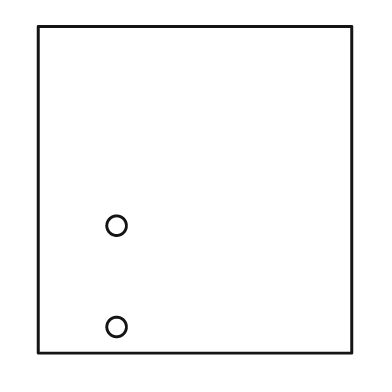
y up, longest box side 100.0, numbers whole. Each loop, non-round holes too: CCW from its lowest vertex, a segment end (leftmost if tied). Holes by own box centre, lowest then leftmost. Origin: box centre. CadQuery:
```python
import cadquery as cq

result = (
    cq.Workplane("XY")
    .moveTo(-48.0, -50.0)
    .lineTo(48.0, -50.0)
    .lineTo(48.0, 50.0)
    .lineTo(-48.0, 50.0)
    .close()
    .moveTo(-24.0, -42.0)
    .circle(3.0)
    .moveTo(-24.0, -11.0)
    .circle(3.0)
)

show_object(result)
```